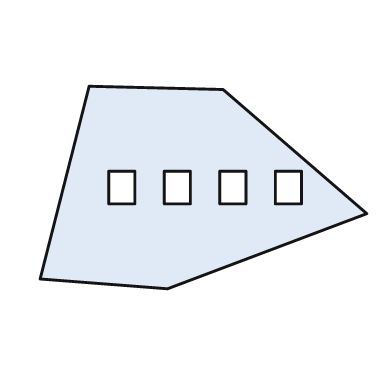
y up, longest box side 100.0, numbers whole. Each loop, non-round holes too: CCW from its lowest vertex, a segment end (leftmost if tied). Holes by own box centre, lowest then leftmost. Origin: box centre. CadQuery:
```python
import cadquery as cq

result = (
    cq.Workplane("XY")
    .moveTo(-11.0, -31.0)
    .lineTo(50.0, -8.0)
    .lineTo(6.0, 30.0)
    .lineTo(-35.0, 31.0)
    .lineTo(-50.0, -28.0)
    .close()
    .moveTo(-29.0, -5.0)
    .lineTo(-21.0, -5.0)
    .lineTo(-21.0, 5.0)
    .lineTo(-29.0, 5.0)
    .close()
    .moveTo(-12.0, -5.0)
    .lineTo(-4.0, -5.0)
    .lineTo(-4.0, 5.0)
    .lineTo(-12.0, 5.0)
    .close()
    .moveTo(5.0, -5.0)
    .lineTo(13.0, -5.0)
    .lineTo(13.0, 5.0)
    .lineTo(5.0, 5.0)
    .close()
    .moveTo(22.0, -5.0)
    .lineTo(30.0, -5.0)
    .lineTo(30.0, 5.0)
    .lineTo(22.0, 5.0)
    .close()
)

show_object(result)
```